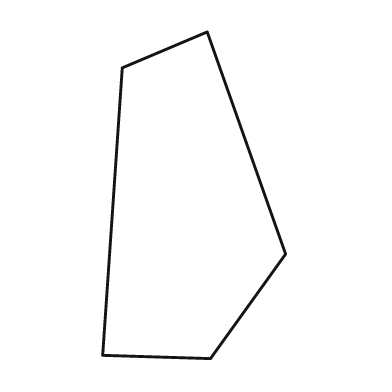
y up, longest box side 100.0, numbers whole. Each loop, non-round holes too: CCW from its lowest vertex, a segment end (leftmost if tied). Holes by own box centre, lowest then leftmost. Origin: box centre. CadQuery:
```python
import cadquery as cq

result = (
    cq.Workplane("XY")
    .moveTo(5.0, -50.0)
    .lineTo(28.0, -18.0)
    .lineTo(4.0, 50.0)
    .lineTo(-22.0, 39.0)
    .lineTo(-28.0, -49.0)
    .close()
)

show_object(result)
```